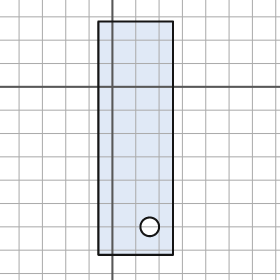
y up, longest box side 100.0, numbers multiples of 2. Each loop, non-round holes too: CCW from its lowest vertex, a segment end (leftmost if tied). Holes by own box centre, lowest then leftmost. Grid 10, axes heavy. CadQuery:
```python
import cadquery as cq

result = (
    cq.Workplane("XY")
    .moveTo(-6.0, -72.0)
    .lineTo(26.0, -72.0)
    .lineTo(26.0, 28.0)
    .lineTo(-6.0, 28.0)
    .close()
    .moveTo(16.0, -60.0)
    .circle(4.0)
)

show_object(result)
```